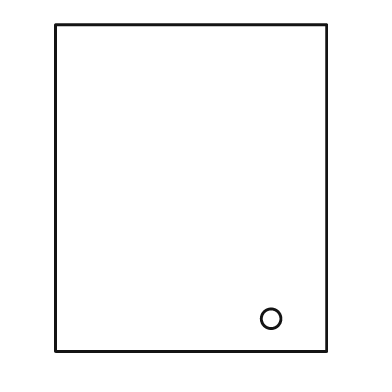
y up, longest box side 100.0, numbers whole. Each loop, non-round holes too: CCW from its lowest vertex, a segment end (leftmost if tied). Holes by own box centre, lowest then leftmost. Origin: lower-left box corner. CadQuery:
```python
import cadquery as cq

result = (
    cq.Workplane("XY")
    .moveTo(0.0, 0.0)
    .lineTo(83.0, 0.0)
    .lineTo(83.0, 100.0)
    .lineTo(0.0, 100.0)
    .close()
    .moveTo(66.0, 10.0)
    .circle(3.0)
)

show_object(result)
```